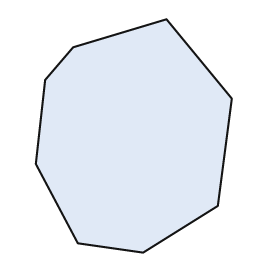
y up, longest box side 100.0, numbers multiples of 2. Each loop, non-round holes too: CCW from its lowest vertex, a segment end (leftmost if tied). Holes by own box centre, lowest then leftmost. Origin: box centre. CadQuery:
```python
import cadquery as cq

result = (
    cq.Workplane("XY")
    .moveTo(4.0, -50.0)
    .lineTo(36.0, -30.0)
    .lineTo(42.0, 16.0)
    .lineTo(14.0, 50.0)
    .lineTo(-26.0, 38.0)
    .lineTo(-38.0, 24.0)
    .lineTo(-42.0, -12.0)
    .lineTo(-24.0, -46.0)
    .close()
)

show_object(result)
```